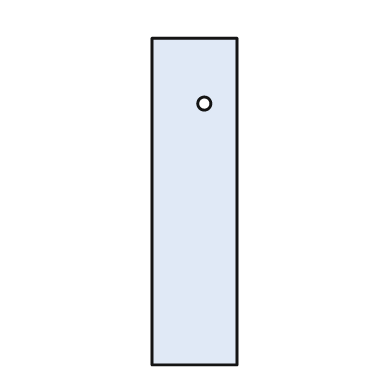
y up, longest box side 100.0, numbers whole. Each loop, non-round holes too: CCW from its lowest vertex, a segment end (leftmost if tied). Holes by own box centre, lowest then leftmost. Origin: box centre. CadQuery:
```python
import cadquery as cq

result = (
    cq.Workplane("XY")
    .moveTo(-13.0, -50.0)
    .lineTo(13.0, -50.0)
    .lineTo(13.0, 50.0)
    .lineTo(-13.0, 50.0)
    .close()
    .moveTo(3.0, 30.0)
    .circle(2.0)
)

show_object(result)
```